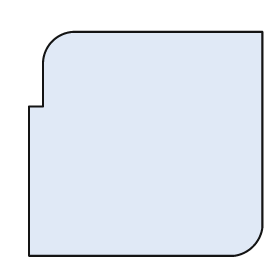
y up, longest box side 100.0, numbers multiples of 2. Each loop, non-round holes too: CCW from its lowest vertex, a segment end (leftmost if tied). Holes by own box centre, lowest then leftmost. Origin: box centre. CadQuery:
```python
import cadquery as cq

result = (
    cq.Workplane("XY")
    .moveTo(-50.0, -48.0)
    .lineTo(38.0, -48.0)
    .threePointArc((46.0, -44.0), (50.0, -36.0))
    .lineTo(50.0, 48.0)
    .lineTo(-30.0, 48.0)
    .threePointArc((-40.0, 44.0), (-44.0, 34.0))
    .lineTo(-44.0, 16.0)
    .lineTo(-50.0, 16.0)
    .close()
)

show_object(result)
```